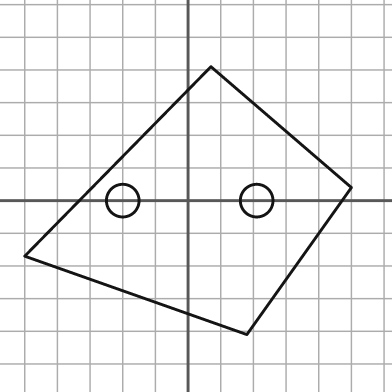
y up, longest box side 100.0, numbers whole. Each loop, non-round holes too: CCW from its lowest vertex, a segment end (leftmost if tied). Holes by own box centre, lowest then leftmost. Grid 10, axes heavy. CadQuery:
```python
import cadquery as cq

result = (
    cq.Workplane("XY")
    .moveTo(18.0, -41.0)
    .lineTo(50.0, 4.0)
    .lineTo(7.0, 41.0)
    .lineTo(-50.0, -17.0)
    .close()
    .moveTo(-20.0, 0.0)
    .circle(5.0)
    .moveTo(21.0, 0.0)
    .circle(5.0)
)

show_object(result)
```